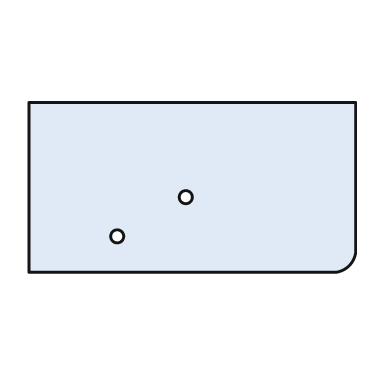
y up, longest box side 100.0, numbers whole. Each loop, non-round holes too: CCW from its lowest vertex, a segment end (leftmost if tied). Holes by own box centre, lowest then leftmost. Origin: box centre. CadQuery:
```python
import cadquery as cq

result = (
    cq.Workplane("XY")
    .moveTo(-50.0, -26.0)
    .lineTo(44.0, -26.0)
    .threePointArc((48.0, -24.0), (50.0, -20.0))
    .lineTo(50.0, 26.0)
    .lineTo(-50.0, 26.0)
    .close()
    .moveTo(-23.0, -15.0)
    .circle(2.0)
    .moveTo(-2.0, -3.0)
    .circle(2.0)
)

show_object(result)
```